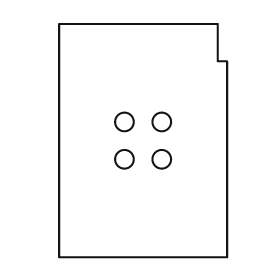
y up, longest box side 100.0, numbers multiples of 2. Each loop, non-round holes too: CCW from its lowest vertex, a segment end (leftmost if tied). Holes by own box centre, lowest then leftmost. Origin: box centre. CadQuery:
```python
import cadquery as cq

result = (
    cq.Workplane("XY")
    .moveTo(-36.0, -50.0)
    .lineTo(36.0, -50.0)
    .lineTo(36.0, 34.0)
    .lineTo(32.0, 34.0)
    .lineTo(32.0, 50.0)
    .lineTo(-36.0, 50.0)
    .close()
    .moveTo(-8.0, -8.0)
    .circle(4.0)
    .moveTo(8.0, -8.0)
    .circle(4.0)
    .moveTo(-8.0, 8.0)
    .circle(4.0)
    .moveTo(8.0, 8.0)
    .circle(4.0)
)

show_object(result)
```